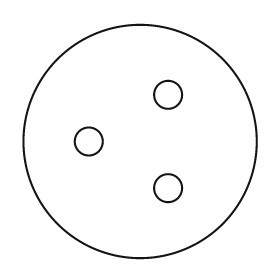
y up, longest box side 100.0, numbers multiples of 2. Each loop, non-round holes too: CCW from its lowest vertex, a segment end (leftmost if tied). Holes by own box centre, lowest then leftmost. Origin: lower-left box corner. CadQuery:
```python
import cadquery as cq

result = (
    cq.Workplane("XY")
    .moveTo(50.0, 50.0)
    .circle(50.0)
    .moveTo(62.0, 30.0)
    .circle(6.0)
    .moveTo(28.0, 50.0)
    .circle(6.0)
    .moveTo(62.0, 70.0)
    .circle(6.0)
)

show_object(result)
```